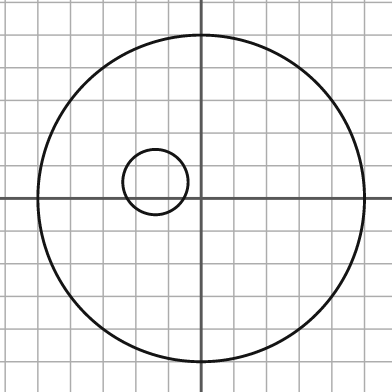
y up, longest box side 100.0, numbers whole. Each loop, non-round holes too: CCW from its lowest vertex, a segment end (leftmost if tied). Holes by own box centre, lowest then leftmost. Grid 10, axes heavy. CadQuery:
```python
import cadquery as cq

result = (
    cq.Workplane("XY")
    .moveTo(0.0, 0.0)
    .circle(50.0)
    .moveTo(-14.0, 5.0)
    .circle(10.0)
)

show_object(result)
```